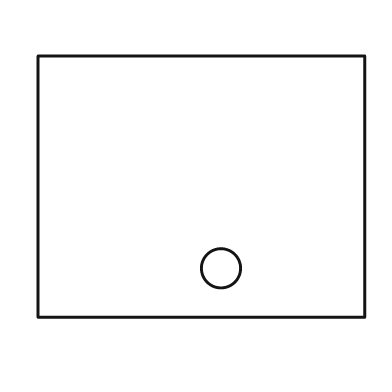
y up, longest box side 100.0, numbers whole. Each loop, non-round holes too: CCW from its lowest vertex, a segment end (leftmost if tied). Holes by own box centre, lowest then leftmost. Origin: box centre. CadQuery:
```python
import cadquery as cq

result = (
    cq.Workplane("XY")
    .moveTo(-50.0, -40.0)
    .lineTo(50.0, -40.0)
    .lineTo(50.0, 40.0)
    .lineTo(-50.0, 40.0)
    .close()
    .moveTo(6.0, -25.0)
    .circle(6.0)
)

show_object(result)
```